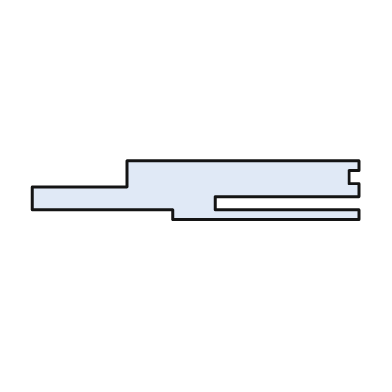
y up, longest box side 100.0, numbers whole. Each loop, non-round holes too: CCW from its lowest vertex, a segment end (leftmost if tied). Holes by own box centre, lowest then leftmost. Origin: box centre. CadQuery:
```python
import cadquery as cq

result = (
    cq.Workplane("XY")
    .moveTo(-7.0, -9.0)
    .lineTo(50.0, -9.0)
    .lineTo(50.0, -6.0)
    .lineTo(6.0, -6.0)
    .lineTo(6.0, -2.0)
    .lineTo(50.0, -2.0)
    .lineTo(50.0, 2.0)
    .lineTo(47.0, 2.0)
    .lineTo(47.0, 6.0)
    .lineTo(50.0, 6.0)
    .lineTo(50.0, 9.0)
    .lineTo(-21.0, 9.0)
    .lineTo(-21.0, 1.0)
    .lineTo(-50.0, 1.0)
    .lineTo(-50.0, -6.0)
    .lineTo(-7.0, -6.0)
    .close()
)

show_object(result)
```